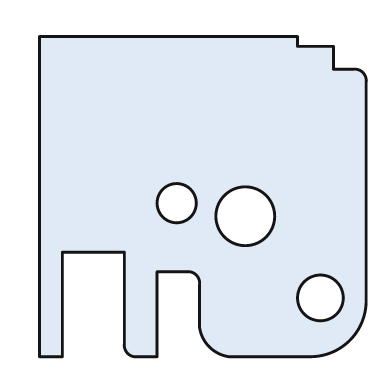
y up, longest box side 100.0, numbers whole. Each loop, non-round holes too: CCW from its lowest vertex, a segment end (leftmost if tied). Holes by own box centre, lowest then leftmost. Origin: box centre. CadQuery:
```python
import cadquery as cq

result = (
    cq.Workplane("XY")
    .moveTo(-50.0, -49.0)
    .lineTo(-43.0, -49.0)
    .lineTo(-43.0, -17.0)
    .lineTo(-24.0, -17.0)
    .lineTo(-24.0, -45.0)
    .threePointArc((-23.0, -48.0), (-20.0, -49.0))
    .lineTo(-14.0, -49.0)
    .lineTo(-14.0, -23.0)
    .lineTo(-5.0, -23.0)
    .threePointArc((-2.0, -24.0), (-1.0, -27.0))
    .lineTo(-1.0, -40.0)
    .threePointArc((2.0, -46.0), (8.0, -49.0))
    .lineTo(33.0, -49.0)
    .threePointArc((45.0, -44.0), (50.0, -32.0))
    .lineTo(50.0, 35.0)
    .threePointArc((49.0, 38.0), (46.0, 39.0))
    .lineTo(40.0, 39.0)
    .lineTo(40.0, 46.0)
    .lineTo(29.0, 46.0)
    .lineTo(29.0, 49.0)
    .lineTo(-50.0, 49.0)
    .close()
    .moveTo(36.0, -31.0)
    .circle(7.0)
    .moveTo(13.0, -6.0)
    .circle(9.0)
    .moveTo(-8.0, -2.0)
    .circle(6.0)
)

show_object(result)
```